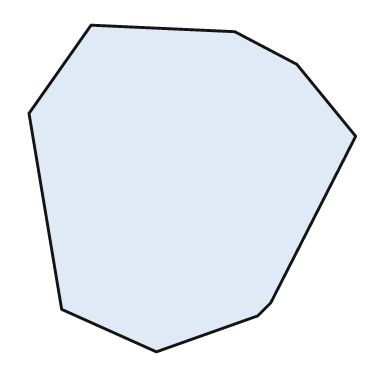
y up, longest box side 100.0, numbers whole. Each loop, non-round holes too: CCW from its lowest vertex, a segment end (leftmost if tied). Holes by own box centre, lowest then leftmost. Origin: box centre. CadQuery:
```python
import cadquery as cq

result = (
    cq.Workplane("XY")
    .moveTo(-11.0, -50.0)
    .lineTo(20.0, -39.0)
    .lineTo(24.0, -35.0)
    .lineTo(50.0, 16.0)
    .lineTo(32.0, 38.0)
    .lineTo(13.0, 48.0)
    .lineTo(-31.0, 50.0)
    .lineTo(-50.0, 23.0)
    .lineTo(-40.0, -37.0)
    .close()
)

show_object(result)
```